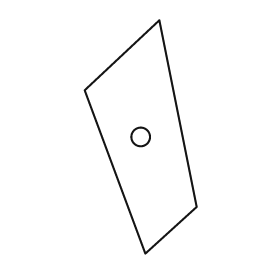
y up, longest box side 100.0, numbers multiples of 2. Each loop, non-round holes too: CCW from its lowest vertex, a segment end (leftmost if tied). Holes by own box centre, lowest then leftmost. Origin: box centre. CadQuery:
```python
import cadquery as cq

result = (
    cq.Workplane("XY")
    .moveTo(2.0, -50.0)
    .lineTo(24.0, -30.0)
    .lineTo(8.0, 50.0)
    .lineTo(-24.0, 20.0)
    .close()
    .moveTo(0.0, 0.0)
    .circle(4.0)
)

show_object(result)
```